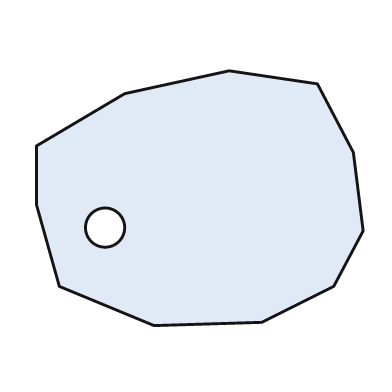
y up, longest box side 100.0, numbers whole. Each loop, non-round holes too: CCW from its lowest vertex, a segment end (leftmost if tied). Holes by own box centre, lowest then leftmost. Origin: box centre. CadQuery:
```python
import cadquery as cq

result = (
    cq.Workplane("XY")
    .moveTo(-14.0, -39.0)
    .lineTo(19.0, -38.0)
    .lineTo(41.0, -27.0)
    .lineTo(50.0, -10.0)
    .lineTo(47.0, 14.0)
    .lineTo(36.0, 35.0)
    .lineTo(9.0, 39.0)
    .lineTo(-23.0, 32.0)
    .lineTo(-50.0, 16.0)
    .lineTo(-50.0, -2.0)
    .lineTo(-43.0, -27.0)
    .close()
    .moveTo(-29.0, -9.0)
    .circle(6.0)
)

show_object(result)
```